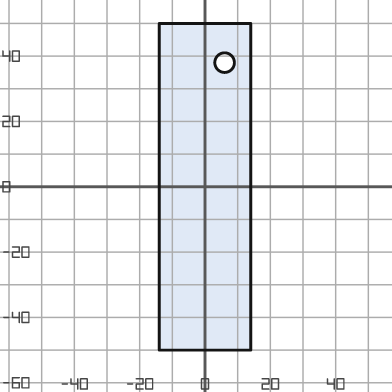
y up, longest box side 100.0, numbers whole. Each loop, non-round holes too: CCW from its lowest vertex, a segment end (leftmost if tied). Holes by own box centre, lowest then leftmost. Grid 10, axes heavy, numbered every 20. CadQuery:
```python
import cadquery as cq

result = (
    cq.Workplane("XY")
    .moveTo(-14.0, -50.0)
    .lineTo(14.0, -50.0)
    .lineTo(14.0, 50.0)
    .lineTo(-14.0, 50.0)
    .close()
    .moveTo(6.0, 38.0)
    .circle(3.0)
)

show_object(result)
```